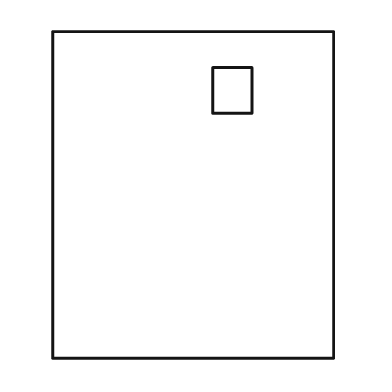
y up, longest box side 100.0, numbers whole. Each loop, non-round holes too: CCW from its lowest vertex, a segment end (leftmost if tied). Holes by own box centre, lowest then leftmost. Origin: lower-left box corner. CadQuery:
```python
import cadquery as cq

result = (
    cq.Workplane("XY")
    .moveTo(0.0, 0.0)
    .lineTo(86.0, 0.0)
    .lineTo(86.0, 100.0)
    .lineTo(0.0, 100.0)
    .close()
    .moveTo(49.0, 75.0)
    .lineTo(61.0, 75.0)
    .lineTo(61.0, 89.0)
    .lineTo(49.0, 89.0)
    .close()
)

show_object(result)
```